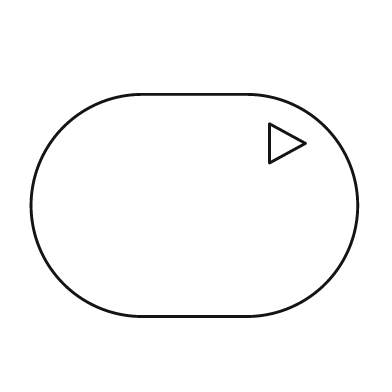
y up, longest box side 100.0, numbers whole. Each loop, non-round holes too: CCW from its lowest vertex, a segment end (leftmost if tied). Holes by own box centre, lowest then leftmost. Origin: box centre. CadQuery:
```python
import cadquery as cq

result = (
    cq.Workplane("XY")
    .moveTo(-16.0, -34.0)
    .lineTo(16.0, -34.0)
    .threePointArc((50.0, 0.0), (16.0, 34.0))
    .lineTo(-16.0, 34.0)
    .threePointArc((-50.0, 0.0), (-16.0, -34.0))
    .close()
    .moveTo(23.0, 13.0)
    .lineTo(34.0, 19.0)
    .lineTo(23.0, 25.0)
    .close()
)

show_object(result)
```